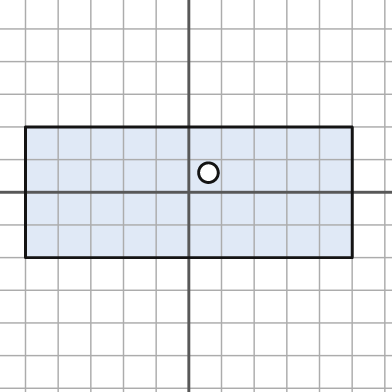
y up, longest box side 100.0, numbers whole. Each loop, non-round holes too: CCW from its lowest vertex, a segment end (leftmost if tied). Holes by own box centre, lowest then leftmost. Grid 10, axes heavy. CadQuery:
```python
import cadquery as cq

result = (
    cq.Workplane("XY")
    .moveTo(-50.0, -20.0)
    .lineTo(50.0, -20.0)
    .lineTo(50.0, 20.0)
    .lineTo(-50.0, 20.0)
    .close()
    .moveTo(6.0, 6.0)
    .circle(3.0)
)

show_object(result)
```